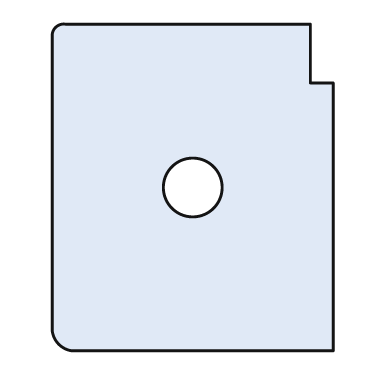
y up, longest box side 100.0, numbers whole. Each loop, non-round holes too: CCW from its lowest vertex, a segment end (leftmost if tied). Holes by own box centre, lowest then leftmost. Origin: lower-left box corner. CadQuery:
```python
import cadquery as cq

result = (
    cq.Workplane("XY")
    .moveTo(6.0, 0.0)
    .lineTo(86.0, 0.0)
    .lineTo(86.0, 82.0)
    .lineTo(79.0, 82.0)
    .lineTo(79.0, 100.0)
    .lineTo(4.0, 100.0)
    .threePointArc((1.0, 99.0), (0.0, 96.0))
    .lineTo(0.0, 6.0)
    .threePointArc((2.0, 2.0), (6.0, 0.0))
    .close()
    .moveTo(43.0, 50.0)
    .circle(9.0)
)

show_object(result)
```